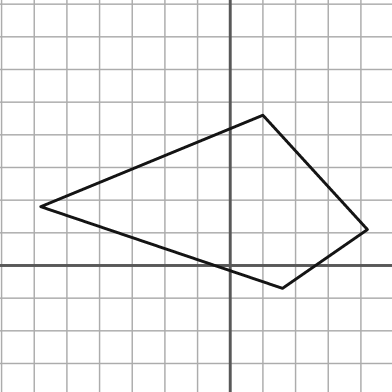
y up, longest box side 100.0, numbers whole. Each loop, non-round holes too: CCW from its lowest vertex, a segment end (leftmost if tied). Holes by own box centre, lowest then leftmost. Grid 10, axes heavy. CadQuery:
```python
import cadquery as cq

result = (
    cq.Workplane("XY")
    .moveTo(16.0, -7.0)
    .lineTo(42.0, 11.0)
    .lineTo(10.0, 46.0)
    .lineTo(-58.0, 18.0)
    .close()
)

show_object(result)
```